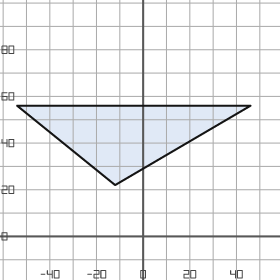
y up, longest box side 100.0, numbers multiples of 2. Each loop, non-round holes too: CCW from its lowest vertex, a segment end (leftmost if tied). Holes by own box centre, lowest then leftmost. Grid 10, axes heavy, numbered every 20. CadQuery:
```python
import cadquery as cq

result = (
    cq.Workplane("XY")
    .moveTo(-12.0, 22.0)
    .lineTo(46.0, 56.0)
    .lineTo(-54.0, 56.0)
    .close()
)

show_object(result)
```